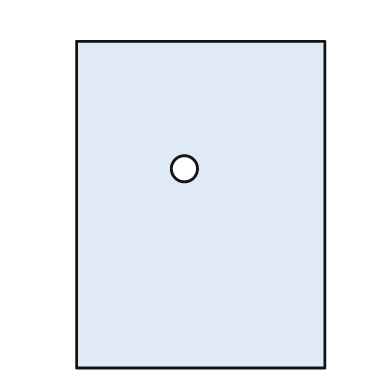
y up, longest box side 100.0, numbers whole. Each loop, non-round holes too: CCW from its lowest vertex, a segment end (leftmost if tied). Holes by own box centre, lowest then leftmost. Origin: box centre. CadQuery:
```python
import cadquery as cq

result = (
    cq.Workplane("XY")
    .moveTo(-38.0, -50.0)
    .lineTo(38.0, -50.0)
    .lineTo(38.0, 50.0)
    .lineTo(-38.0, 50.0)
    .close()
    .moveTo(-5.0, 11.0)
    .circle(4.0)
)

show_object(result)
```